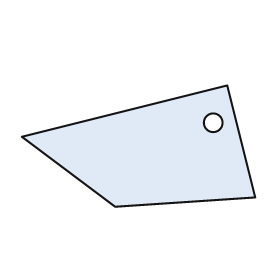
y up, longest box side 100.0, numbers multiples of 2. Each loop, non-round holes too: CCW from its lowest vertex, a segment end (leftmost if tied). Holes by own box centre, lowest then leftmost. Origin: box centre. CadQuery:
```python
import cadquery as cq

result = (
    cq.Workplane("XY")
    .moveTo(-10.0, -26.0)
    .lineTo(50.0, -22.0)
    .lineTo(38.0, 26.0)
    .lineTo(-50.0, 4.0)
    .close()
    .moveTo(32.0, 10.0)
    .circle(4.0)
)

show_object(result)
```